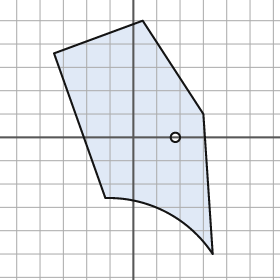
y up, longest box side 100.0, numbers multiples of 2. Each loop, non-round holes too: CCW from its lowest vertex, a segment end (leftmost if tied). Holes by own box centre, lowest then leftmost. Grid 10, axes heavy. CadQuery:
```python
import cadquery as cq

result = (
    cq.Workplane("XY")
    .moveTo(34.0, -50.0)
    .lineTo(30.0, 10.0)
    .lineTo(4.0, 50.0)
    .lineTo(-34.0, 36.0)
    .lineTo(-12.0, -26.0)
    .threePointArc((14.0, -32.0), (34.0, -50.0))
    .close()
    .moveTo(18.0, 0.0)
    .circle(2.0)
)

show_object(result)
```